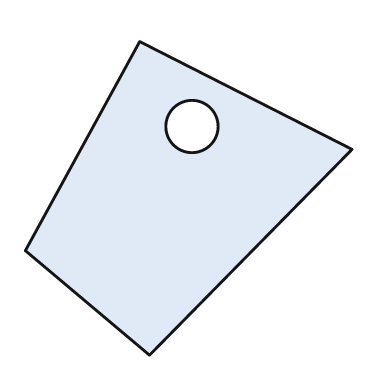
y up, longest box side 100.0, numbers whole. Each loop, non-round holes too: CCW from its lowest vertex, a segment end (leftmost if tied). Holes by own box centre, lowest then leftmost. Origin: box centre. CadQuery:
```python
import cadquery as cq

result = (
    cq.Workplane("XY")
    .moveTo(-12.0, -48.0)
    .lineTo(50.0, 15.0)
    .lineTo(-15.0, 48.0)
    .lineTo(-50.0, -16.0)
    .close()
    .moveTo(1.0, 22.0)
    .circle(8.0)
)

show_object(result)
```